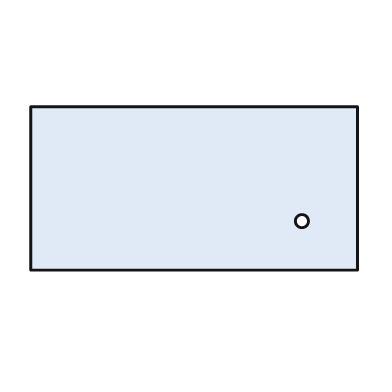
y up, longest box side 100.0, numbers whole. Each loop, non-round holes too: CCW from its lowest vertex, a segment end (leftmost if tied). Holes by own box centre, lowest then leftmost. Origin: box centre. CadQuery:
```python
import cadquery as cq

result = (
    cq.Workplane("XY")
    .moveTo(-50.0, -25.0)
    .lineTo(50.0, -25.0)
    .lineTo(50.0, 25.0)
    .lineTo(-50.0, 25.0)
    .close()
    .moveTo(33.0, -10.0)
    .circle(2.0)
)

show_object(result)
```